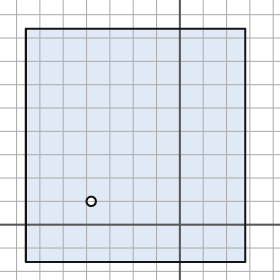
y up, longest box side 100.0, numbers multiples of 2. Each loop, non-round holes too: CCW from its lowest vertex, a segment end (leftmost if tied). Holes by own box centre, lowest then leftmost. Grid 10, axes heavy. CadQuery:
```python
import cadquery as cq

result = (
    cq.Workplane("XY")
    .moveTo(-66.0, -16.0)
    .lineTo(28.0, -16.0)
    .lineTo(28.0, 84.0)
    .lineTo(-66.0, 84.0)
    .close()
    .moveTo(-38.0, 10.0)
    .circle(2.0)
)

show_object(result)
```